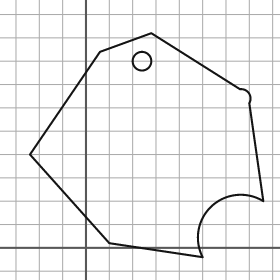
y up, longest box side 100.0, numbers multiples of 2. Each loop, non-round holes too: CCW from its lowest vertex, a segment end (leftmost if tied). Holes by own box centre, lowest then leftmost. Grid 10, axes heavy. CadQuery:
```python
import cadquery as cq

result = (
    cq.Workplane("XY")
    .moveTo(50.0, -4.0)
    .threePointArc((54.0, 18.0), (76.0, 20.0))
    .lineTo(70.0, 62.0)
    .threePointArc((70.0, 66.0), (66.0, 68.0))
    .lineTo(28.0, 92.0)
    .lineTo(6.0, 84.0)
    .lineTo(-24.0, 40.0)
    .lineTo(10.0, 2.0)
    .close()
    .moveTo(24.0, 80.0)
    .circle(4.0)
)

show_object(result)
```